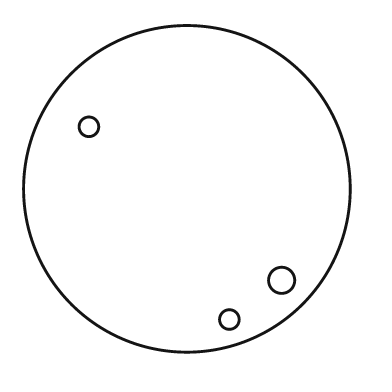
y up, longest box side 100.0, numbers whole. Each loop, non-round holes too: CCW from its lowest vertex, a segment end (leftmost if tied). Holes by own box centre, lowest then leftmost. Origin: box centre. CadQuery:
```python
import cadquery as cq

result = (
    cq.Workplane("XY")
    .moveTo(0.0, 0.0)
    .circle(50.0)
    .moveTo(13.0, -40.0)
    .circle(3.0)
    .moveTo(29.0, -28.0)
    .circle(4.0)
    .moveTo(-30.0, 19.0)
    .circle(3.0)
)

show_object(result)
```